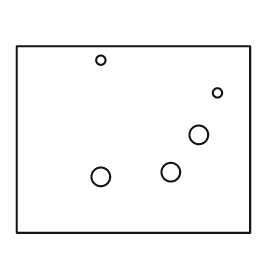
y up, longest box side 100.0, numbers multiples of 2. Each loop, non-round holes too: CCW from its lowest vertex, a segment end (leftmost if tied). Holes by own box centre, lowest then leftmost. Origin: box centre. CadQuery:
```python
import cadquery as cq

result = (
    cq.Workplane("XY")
    .moveTo(-50.0, -40.0)
    .lineTo(50.0, -40.0)
    .lineTo(50.0, 40.0)
    .lineTo(-50.0, 40.0)
    .close()
    .moveTo(-14.0, -16.0)
    .circle(4.0)
    .moveTo(16.0, -14.0)
    .circle(4.0)
    .moveTo(28.0, 2.0)
    .circle(4.0)
    .moveTo(36.0, 20.0)
    .circle(2.0)
    .moveTo(-14.0, 34.0)
    .circle(2.0)
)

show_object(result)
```